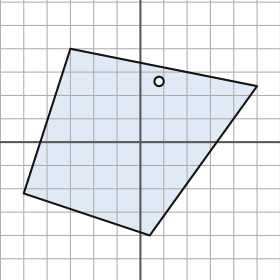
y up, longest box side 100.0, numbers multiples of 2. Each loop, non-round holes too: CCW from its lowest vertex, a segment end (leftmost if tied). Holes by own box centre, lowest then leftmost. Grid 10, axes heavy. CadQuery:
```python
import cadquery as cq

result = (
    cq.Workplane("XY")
    .moveTo(4.0, -40.0)
    .lineTo(50.0, 24.0)
    .lineTo(-30.0, 40.0)
    .lineTo(-50.0, -22.0)
    .close()
    .moveTo(8.0, 26.0)
    .circle(2.0)
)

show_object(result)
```